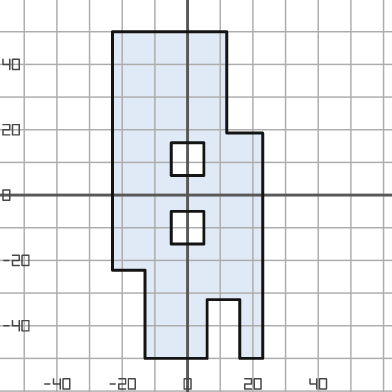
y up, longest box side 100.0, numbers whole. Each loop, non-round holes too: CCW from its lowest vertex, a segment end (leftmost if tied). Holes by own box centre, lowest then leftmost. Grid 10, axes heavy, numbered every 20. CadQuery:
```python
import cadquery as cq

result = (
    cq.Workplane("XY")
    .moveTo(-13.0, -50.0)
    .lineTo(6.0, -50.0)
    .lineTo(6.0, -32.0)
    .lineTo(16.0, -32.0)
    .lineTo(16.0, -50.0)
    .lineTo(23.0, -50.0)
    .lineTo(23.0, 19.0)
    .lineTo(12.0, 19.0)
    .lineTo(12.0, 50.0)
    .lineTo(-23.0, 50.0)
    .lineTo(-23.0, -23.0)
    .lineTo(-13.0, -23.0)
    .close()
    .moveTo(-5.0, -15.0)
    .lineTo(5.0, -15.0)
    .lineTo(5.0, -5.0)
    .lineTo(-5.0, -5.0)
    .close()
    .moveTo(-5.0, 6.0)
    .lineTo(5.0, 6.0)
    .lineTo(5.0, 16.0)
    .lineTo(-5.0, 16.0)
    .close()
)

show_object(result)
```